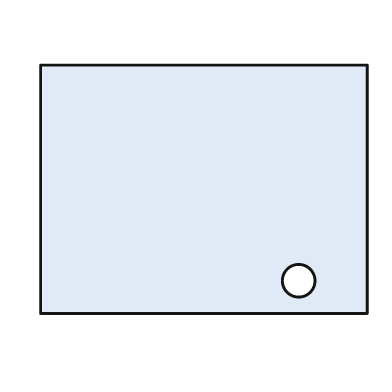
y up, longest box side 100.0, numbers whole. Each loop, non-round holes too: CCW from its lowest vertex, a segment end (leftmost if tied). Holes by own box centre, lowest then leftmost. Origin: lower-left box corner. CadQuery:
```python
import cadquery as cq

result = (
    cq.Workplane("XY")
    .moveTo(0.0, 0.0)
    .lineTo(100.0, 0.0)
    .lineTo(100.0, 76.0)
    .lineTo(0.0, 76.0)
    .close()
    .moveTo(79.0, 10.0)
    .circle(5.0)
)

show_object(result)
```